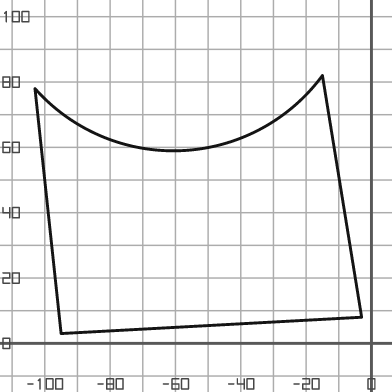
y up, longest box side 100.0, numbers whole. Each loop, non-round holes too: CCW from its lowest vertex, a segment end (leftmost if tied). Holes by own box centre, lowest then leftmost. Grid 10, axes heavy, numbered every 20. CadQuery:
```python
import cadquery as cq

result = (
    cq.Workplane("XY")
    .moveTo(-95.0, 3.0)
    .lineTo(-3.0, 8.0)
    .lineTo(-15.0, 82.0)
    .threePointArc((-58.0, 59.0), (-103.0, 78.0))
    .close()
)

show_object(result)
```